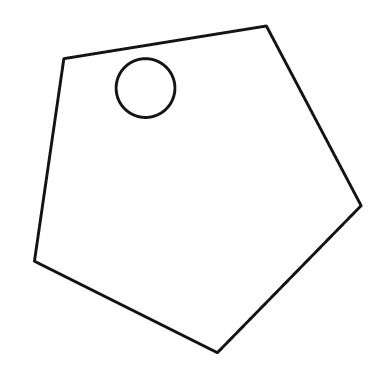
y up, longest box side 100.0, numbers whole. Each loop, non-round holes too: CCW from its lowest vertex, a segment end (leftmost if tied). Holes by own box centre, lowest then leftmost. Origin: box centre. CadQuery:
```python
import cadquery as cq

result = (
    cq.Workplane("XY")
    .moveTo(6.0, -50.0)
    .lineTo(50.0, -5.0)
    .lineTo(21.0, 50.0)
    .lineTo(-41.0, 40.0)
    .lineTo(-50.0, -22.0)
    .close()
    .moveTo(-16.0, 31.0)
    .circle(9.0)
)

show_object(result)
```